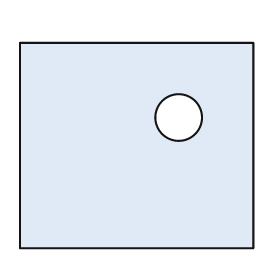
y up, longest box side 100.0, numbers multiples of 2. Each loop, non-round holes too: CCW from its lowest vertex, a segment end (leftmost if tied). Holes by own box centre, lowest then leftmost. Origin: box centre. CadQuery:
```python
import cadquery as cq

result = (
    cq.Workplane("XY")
    .moveTo(-50.0, -44.0)
    .lineTo(50.0, -44.0)
    .lineTo(50.0, 44.0)
    .lineTo(-50.0, 44.0)
    .close()
    .moveTo(18.0, 12.0)
    .circle(10.0)
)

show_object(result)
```